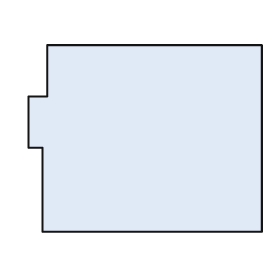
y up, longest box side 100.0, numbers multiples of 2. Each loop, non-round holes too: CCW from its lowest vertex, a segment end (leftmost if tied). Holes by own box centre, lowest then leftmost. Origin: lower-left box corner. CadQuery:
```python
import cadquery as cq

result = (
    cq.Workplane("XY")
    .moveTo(6.0, 0.0)
    .lineTo(100.0, 0.0)
    .lineTo(100.0, 80.0)
    .lineTo(8.0, 80.0)
    .lineTo(8.0, 58.0)
    .lineTo(0.0, 58.0)
    .lineTo(0.0, 36.0)
    .lineTo(6.0, 36.0)
    .close()
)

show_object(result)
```